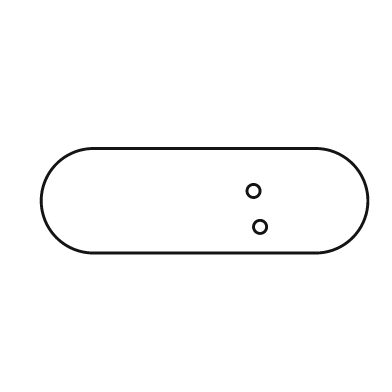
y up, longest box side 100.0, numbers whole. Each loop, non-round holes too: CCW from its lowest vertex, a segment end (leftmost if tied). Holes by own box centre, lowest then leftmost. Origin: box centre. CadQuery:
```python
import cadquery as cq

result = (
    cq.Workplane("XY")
    .moveTo(-34.0, -16.0)
    .lineTo(34.0, -16.0)
    .threePointArc((50.0, 0.0), (34.0, 16.0))
    .lineTo(-34.0, 16.0)
    .threePointArc((-50.0, 0.0), (-34.0, -16.0))
    .close()
    .moveTo(17.0, -8.0)
    .circle(2.0)
    .moveTo(15.0, 3.0)
    .circle(2.0)
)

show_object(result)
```